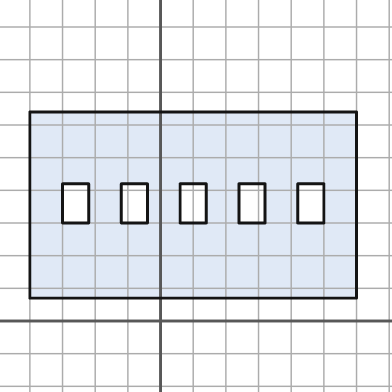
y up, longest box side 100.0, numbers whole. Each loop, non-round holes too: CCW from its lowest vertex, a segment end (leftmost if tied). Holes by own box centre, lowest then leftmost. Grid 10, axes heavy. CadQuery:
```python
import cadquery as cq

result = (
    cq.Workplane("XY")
    .moveTo(-40.0, 7.0)
    .lineTo(60.0, 7.0)
    .lineTo(60.0, 64.0)
    .lineTo(-40.0, 64.0)
    .close()
    .moveTo(-30.0, 30.0)
    .lineTo(-22.0, 30.0)
    .lineTo(-22.0, 42.0)
    .lineTo(-30.0, 42.0)
    .close()
    .moveTo(-12.0, 30.0)
    .lineTo(-4.0, 30.0)
    .lineTo(-4.0, 42.0)
    .lineTo(-12.0, 42.0)
    .close()
    .moveTo(6.0, 30.0)
    .lineTo(14.0, 30.0)
    .lineTo(14.0, 42.0)
    .lineTo(6.0, 42.0)
    .close()
    .moveTo(24.0, 30.0)
    .lineTo(32.0, 30.0)
    .lineTo(32.0, 42.0)
    .lineTo(24.0, 42.0)
    .close()
    .moveTo(42.0, 30.0)
    .lineTo(50.0, 30.0)
    .lineTo(50.0, 42.0)
    .lineTo(42.0, 42.0)
    .close()
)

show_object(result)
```